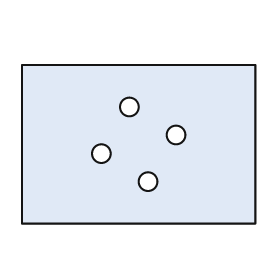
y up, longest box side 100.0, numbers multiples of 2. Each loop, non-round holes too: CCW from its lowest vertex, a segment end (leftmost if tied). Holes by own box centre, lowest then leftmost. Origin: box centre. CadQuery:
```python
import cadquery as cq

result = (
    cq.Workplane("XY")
    .moveTo(-50.0, -34.0)
    .lineTo(50.0, -34.0)
    .lineTo(50.0, 34.0)
    .lineTo(-50.0, 34.0)
    .close()
    .moveTo(4.0, -16.0)
    .circle(4.0)
    .moveTo(-16.0, -4.0)
    .circle(4.0)
    .moveTo(16.0, 4.0)
    .circle(4.0)
    .moveTo(-4.0, 16.0)
    .circle(4.0)
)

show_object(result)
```